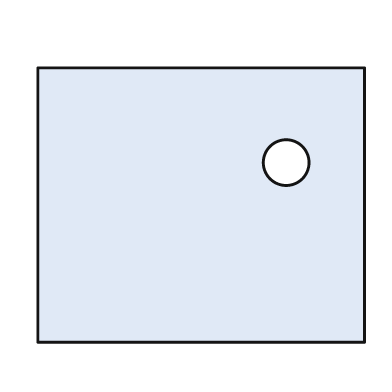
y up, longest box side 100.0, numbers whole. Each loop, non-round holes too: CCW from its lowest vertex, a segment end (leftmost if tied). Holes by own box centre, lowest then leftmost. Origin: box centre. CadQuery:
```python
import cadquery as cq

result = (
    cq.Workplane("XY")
    .moveTo(-50.0, -42.0)
    .lineTo(50.0, -42.0)
    .lineTo(50.0, 42.0)
    .lineTo(-50.0, 42.0)
    .close()
    .moveTo(26.0, 13.0)
    .circle(7.0)
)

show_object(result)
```